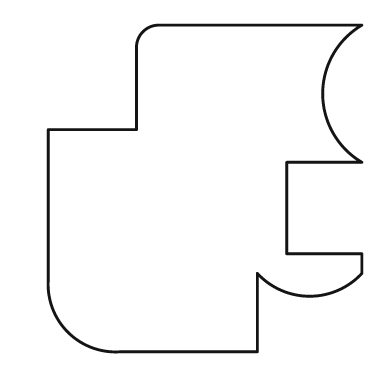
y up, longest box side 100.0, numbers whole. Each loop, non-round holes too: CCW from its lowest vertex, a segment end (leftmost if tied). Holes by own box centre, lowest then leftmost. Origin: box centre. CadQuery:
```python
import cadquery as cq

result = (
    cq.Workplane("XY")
    .moveTo(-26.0, -50.0)
    .lineTo(16.0, -50.0)
    .lineTo(16.0, -26.0)
    .threePointArc((32.0, -33.0), (48.0, -26.0))
    .lineTo(48.0, -20.0)
    .lineTo(25.0, -20.0)
    .lineTo(25.0, 8.0)
    .lineTo(48.0, 8.0)
    .threePointArc((36.0, 29.0), (48.0, 50.0))
    .lineTo(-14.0, 50.0)
    .threePointArc((-19.0, 48.0), (-21.0, 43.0))
    .lineTo(-21.0, 18.0)
    .lineTo(-48.0, 18.0)
    .lineTo(-48.0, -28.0)
    .threePointArc((-42.0, -44.0), (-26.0, -50.0))
    .close()
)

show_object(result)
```